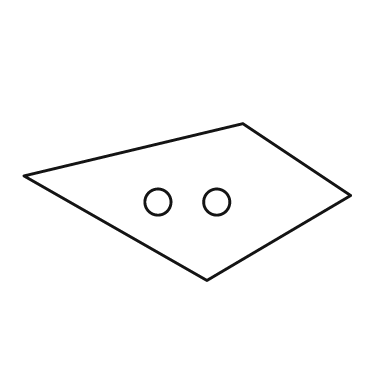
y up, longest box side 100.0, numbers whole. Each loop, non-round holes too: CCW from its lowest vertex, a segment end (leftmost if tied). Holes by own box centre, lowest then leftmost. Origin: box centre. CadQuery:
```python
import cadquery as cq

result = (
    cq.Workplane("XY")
    .moveTo(6.0, -24.0)
    .lineTo(50.0, 2.0)
    .lineTo(17.0, 24.0)
    .lineTo(-50.0, 8.0)
    .close()
    .moveTo(-9.0, 0.0)
    .circle(4.0)
    .moveTo(9.0, 0.0)
    .circle(4.0)
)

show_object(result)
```